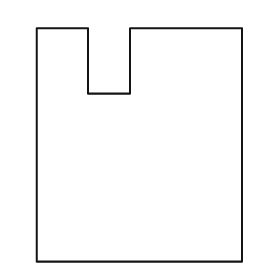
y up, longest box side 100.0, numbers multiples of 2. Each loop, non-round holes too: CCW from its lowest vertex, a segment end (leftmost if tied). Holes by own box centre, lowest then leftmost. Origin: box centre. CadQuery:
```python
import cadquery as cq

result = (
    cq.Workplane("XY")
    .moveTo(-44.0, -50.0)
    .lineTo(44.0, -50.0)
    .lineTo(44.0, 50.0)
    .lineTo(-4.0, 50.0)
    .lineTo(-4.0, 22.0)
    .lineTo(-22.0, 22.0)
    .lineTo(-22.0, 50.0)
    .lineTo(-44.0, 50.0)
    .close()
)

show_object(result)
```